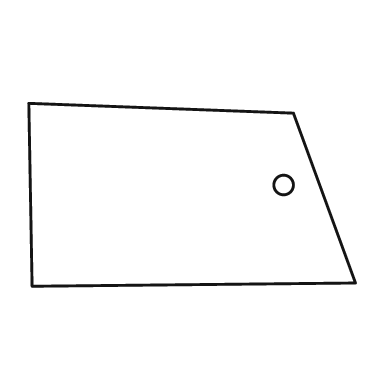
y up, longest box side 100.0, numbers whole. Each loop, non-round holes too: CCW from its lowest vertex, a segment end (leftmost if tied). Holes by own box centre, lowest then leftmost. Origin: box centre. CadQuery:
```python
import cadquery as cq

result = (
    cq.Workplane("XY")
    .moveTo(-49.0, -28.0)
    .lineTo(50.0, -27.0)
    .lineTo(31.0, 25.0)
    .lineTo(-50.0, 28.0)
    .close()
    .moveTo(28.0, 3.0)
    .circle(3.0)
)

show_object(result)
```